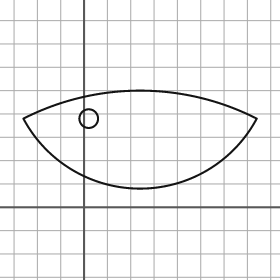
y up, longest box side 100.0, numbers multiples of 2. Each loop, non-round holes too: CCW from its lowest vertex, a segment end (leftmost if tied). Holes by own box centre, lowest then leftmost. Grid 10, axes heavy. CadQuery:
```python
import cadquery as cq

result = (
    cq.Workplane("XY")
    .moveTo(-26.0, 38.0)
    .threePointArc((24.0, 8.0), (74.0, 38.0))
    .threePointArc((24.0, 50.0), (-26.0, 38.0))
    .close()
    .moveTo(2.0, 38.0)
    .circle(4.0)
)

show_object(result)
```